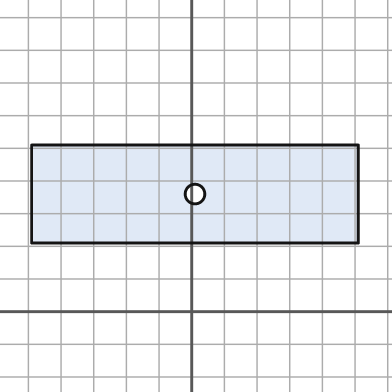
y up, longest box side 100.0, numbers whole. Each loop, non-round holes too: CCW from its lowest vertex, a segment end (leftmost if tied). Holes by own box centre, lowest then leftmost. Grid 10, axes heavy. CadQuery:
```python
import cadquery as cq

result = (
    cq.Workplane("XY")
    .moveTo(-49.0, 21.0)
    .lineTo(51.0, 21.0)
    .lineTo(51.0, 51.0)
    .lineTo(-49.0, 51.0)
    .close()
    .moveTo(1.0, 36.0)
    .circle(3.0)
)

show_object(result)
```